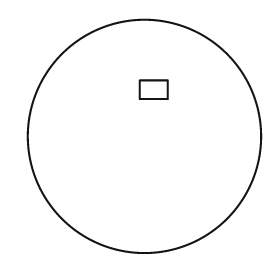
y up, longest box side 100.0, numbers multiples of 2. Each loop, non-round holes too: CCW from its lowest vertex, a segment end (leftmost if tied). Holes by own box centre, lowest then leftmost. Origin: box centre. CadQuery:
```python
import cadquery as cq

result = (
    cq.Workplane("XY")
    .moveTo(0.0, 0.0)
    .circle(50.0)
    .moveTo(-2.0, 16.0)
    .lineTo(10.0, 16.0)
    .lineTo(10.0, 24.0)
    .lineTo(-2.0, 24.0)
    .close()
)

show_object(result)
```